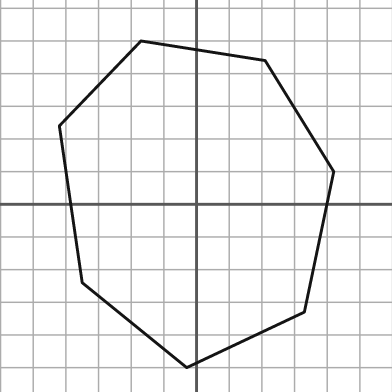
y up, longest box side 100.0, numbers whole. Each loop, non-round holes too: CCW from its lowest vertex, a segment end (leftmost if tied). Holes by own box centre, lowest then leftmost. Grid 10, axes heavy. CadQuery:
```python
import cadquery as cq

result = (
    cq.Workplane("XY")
    .moveTo(-3.0, -50.0)
    .lineTo(33.0, -33.0)
    .lineTo(42.0, 10.0)
    .lineTo(21.0, 44.0)
    .lineTo(-17.0, 50.0)
    .lineTo(-42.0, 24.0)
    .lineTo(-35.0, -24.0)
    .close()
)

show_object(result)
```